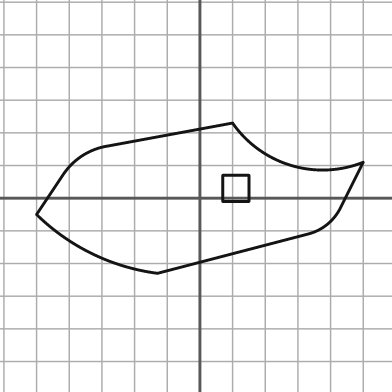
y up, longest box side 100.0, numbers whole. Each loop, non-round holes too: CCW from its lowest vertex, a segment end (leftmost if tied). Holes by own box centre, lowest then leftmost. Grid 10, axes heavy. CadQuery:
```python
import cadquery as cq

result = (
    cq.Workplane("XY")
    .moveTo(-13.0, -23.0)
    .lineTo(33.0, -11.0)
    .threePointArc((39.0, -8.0), (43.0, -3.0))
    .lineTo(50.0, 11.0)
    .threePointArc((28.0, 10.0), (10.0, 23.0))
    .lineTo(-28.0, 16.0)
    .threePointArc((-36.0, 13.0), (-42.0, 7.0))
    .lineTo(-50.0, -5.0)
    .threePointArc((-33.0, -17.0), (-13.0, -23.0))
    .close()
    .moveTo(7.0, -1.0)
    .lineTo(15.0, -1.0)
    .lineTo(15.0, 7.0)
    .lineTo(7.0, 7.0)
    .close()
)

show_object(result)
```